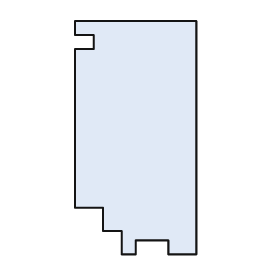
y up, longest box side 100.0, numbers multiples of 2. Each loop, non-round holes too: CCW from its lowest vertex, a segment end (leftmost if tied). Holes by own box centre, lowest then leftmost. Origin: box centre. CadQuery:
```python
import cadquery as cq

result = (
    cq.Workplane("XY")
    .moveTo(-6.0, -50.0)
    .lineTo(0.0, -50.0)
    .lineTo(0.0, -44.0)
    .lineTo(14.0, -44.0)
    .lineTo(14.0, -50.0)
    .lineTo(26.0, -50.0)
    .lineTo(26.0, 50.0)
    .lineTo(-26.0, 50.0)
    .lineTo(-26.0, 44.0)
    .lineTo(-18.0, 44.0)
    .lineTo(-18.0, 38.0)
    .lineTo(-26.0, 38.0)
    .lineTo(-26.0, -30.0)
    .lineTo(-14.0, -30.0)
    .lineTo(-14.0, -40.0)
    .lineTo(-6.0, -40.0)
    .close()
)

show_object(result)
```